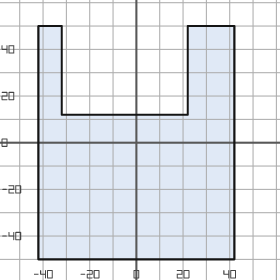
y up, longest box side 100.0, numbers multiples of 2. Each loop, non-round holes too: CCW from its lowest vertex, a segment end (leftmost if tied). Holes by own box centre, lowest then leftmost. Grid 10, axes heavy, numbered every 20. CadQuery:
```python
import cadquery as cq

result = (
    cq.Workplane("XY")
    .moveTo(-42.0, -50.0)
    .lineTo(42.0, -50.0)
    .lineTo(42.0, 50.0)
    .lineTo(22.0, 50.0)
    .lineTo(22.0, 12.0)
    .lineTo(-32.0, 12.0)
    .lineTo(-32.0, 50.0)
    .lineTo(-42.0, 50.0)
    .close()
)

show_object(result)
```